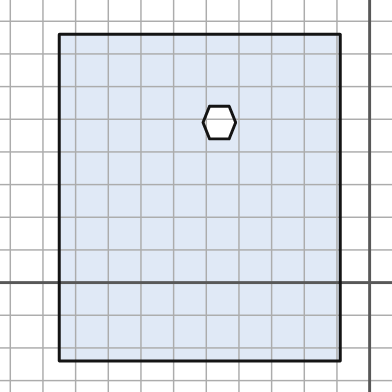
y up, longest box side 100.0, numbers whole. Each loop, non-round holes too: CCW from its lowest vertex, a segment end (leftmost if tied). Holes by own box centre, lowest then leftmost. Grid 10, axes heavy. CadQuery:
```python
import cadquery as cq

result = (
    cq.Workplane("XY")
    .moveTo(-95.0, -24.0)
    .lineTo(-9.0, -24.0)
    .lineTo(-9.0, 76.0)
    .lineTo(-95.0, 76.0)
    .close()
    .moveTo(-49.0, 44.0)
    .lineTo(-43.0, 44.0)
    .lineTo(-41.0, 49.0)
    .lineTo(-43.0, 54.0)
    .lineTo(-49.0, 54.0)
    .lineTo(-51.0, 49.0)
    .close()
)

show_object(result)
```